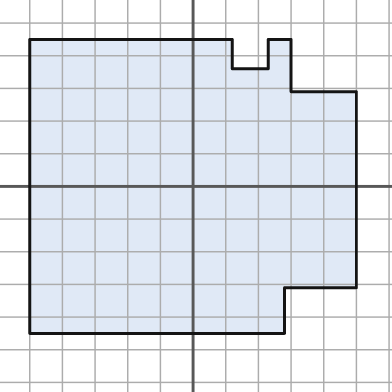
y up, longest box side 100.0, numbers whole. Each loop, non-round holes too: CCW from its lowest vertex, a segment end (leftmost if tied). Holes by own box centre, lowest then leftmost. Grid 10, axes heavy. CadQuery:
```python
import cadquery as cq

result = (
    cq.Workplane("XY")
    .moveTo(-50.0, -45.0)
    .lineTo(28.0, -45.0)
    .lineTo(28.0, -31.0)
    .lineTo(50.0, -31.0)
    .lineTo(50.0, 29.0)
    .lineTo(30.0, 29.0)
    .lineTo(30.0, 45.0)
    .lineTo(23.0, 45.0)
    .lineTo(23.0, 36.0)
    .lineTo(12.0, 36.0)
    .lineTo(12.0, 45.0)
    .lineTo(-50.0, 45.0)
    .close()
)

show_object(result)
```